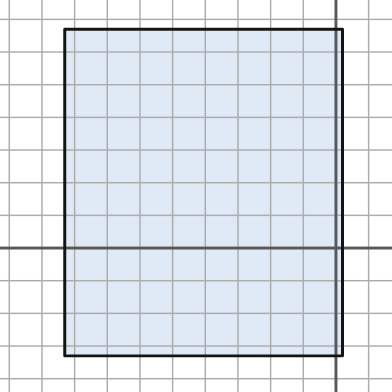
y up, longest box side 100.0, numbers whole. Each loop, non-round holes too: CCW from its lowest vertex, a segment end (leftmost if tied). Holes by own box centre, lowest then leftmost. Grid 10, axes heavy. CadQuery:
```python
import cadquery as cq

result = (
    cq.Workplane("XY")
    .moveTo(-83.0, -33.0)
    .lineTo(2.0, -33.0)
    .lineTo(2.0, 67.0)
    .lineTo(-83.0, 67.0)
    .close()
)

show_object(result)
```